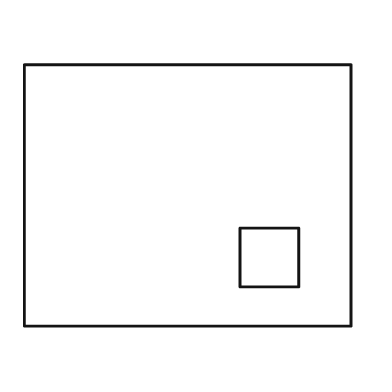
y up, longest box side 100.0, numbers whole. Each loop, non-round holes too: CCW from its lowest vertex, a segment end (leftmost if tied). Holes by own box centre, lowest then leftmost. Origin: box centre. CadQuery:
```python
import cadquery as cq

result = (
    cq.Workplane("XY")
    .moveTo(-50.0, -40.0)
    .lineTo(50.0, -40.0)
    .lineTo(50.0, 40.0)
    .lineTo(-50.0, 40.0)
    .close()
    .moveTo(16.0, -28.0)
    .lineTo(34.0, -28.0)
    .lineTo(34.0, -10.0)
    .lineTo(16.0, -10.0)
    .close()
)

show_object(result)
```